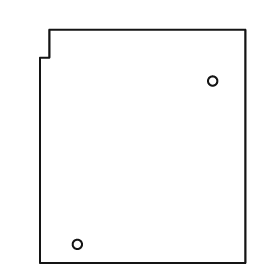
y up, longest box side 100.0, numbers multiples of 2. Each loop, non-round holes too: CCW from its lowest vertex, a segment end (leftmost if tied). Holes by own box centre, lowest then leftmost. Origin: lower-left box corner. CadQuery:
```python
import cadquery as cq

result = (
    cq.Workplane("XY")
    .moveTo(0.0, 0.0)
    .lineTo(88.0, 0.0)
    .lineTo(88.0, 100.0)
    .lineTo(4.0, 100.0)
    .lineTo(4.0, 88.0)
    .lineTo(0.0, 88.0)
    .close()
    .moveTo(16.0, 8.0)
    .circle(2.0)
    .moveTo(74.0, 78.0)
    .circle(2.0)
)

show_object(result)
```